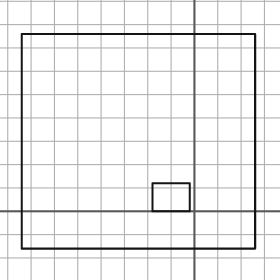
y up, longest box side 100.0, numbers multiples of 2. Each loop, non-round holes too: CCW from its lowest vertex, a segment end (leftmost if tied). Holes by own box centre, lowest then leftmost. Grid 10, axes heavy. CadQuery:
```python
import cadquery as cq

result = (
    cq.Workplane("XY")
    .moveTo(-74.0, -16.0)
    .lineTo(26.0, -16.0)
    .lineTo(26.0, 76.0)
    .lineTo(-74.0, 76.0)
    .close()
    .moveTo(-18.0, 0.0)
    .lineTo(-2.0, 0.0)
    .lineTo(-2.0, 12.0)
    .lineTo(-18.0, 12.0)
    .close()
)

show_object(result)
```